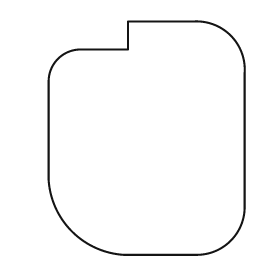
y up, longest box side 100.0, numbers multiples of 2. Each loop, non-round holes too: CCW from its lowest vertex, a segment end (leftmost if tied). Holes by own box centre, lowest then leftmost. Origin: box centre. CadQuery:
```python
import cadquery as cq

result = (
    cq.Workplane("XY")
    .moveTo(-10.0, -50.0)
    .lineTo(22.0, -50.0)
    .threePointArc((36.0, -44.0), (42.0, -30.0))
    .lineTo(42.0, 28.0)
    .threePointArc((36.0, 44.0), (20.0, 50.0))
    .lineTo(-8.0, 50.0)
    .lineTo(-8.0, 38.0)
    .lineTo(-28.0, 38.0)
    .threePointArc((-38.0, 34.0), (-42.0, 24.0))
    .lineTo(-42.0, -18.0)
    .threePointArc((-32.0, -40.0), (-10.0, -50.0))
    .close()
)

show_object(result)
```